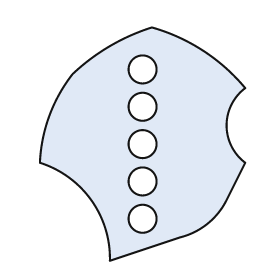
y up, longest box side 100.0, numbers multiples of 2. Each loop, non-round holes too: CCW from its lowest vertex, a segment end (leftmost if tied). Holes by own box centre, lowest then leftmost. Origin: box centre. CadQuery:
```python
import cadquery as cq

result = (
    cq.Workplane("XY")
    .moveTo(-14.0, -50.0)
    .lineTo(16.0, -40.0)
    .threePointArc((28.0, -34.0), (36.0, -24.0))
    .lineTo(44.0, -8.0)
    .threePointArc((36.0, 8.0), (44.0, 24.0))
    .threePointArc((26.0, 40.0), (4.0, 50.0))
    .threePointArc((-14.0, 42.0), (-30.0, 30.0))
    .threePointArc((-40.0, 12.0), (-44.0, -8.0))
    .threePointArc((-22.0, -24.0), (-14.0, -50.0))
    .close()
    .moveTo(0.0, -32.0)
    .circle(6.0)
    .moveTo(0.0, -16.0)
    .circle(6.0)
    .moveTo(0.0, 0.0)
    .circle(6.0)
    .moveTo(0.0, 16.0)
    .circle(6.0)
    .moveTo(0.0, 32.0)
    .circle(6.0)
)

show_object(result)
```